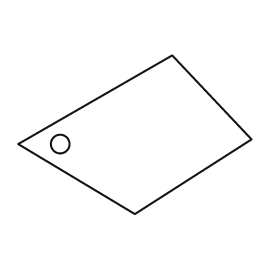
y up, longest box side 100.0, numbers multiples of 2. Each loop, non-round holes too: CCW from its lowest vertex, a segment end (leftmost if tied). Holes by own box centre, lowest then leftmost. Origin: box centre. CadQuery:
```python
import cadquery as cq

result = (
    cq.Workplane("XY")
    .moveTo(0.0, -34.0)
    .lineTo(50.0, -2.0)
    .lineTo(16.0, 34.0)
    .lineTo(-50.0, -4.0)
    .close()
    .moveTo(-32.0, -4.0)
    .circle(4.0)
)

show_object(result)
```